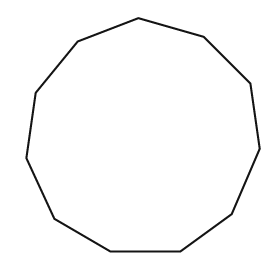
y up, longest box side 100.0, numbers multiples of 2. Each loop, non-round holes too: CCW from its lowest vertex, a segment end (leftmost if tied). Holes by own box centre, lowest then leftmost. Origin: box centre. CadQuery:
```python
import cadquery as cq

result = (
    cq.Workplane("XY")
    .moveTo(-14.0, -50.0)
    .lineTo(16.0, -50.0)
    .lineTo(38.0, -34.0)
    .lineTo(50.0, -6.0)
    .lineTo(46.0, 22.0)
    .lineTo(26.0, 42.0)
    .lineTo(-2.0, 50.0)
    .lineTo(-28.0, 40.0)
    .lineTo(-46.0, 18.0)
    .lineTo(-50.0, -10.0)
    .lineTo(-38.0, -36.0)
    .close()
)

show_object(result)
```